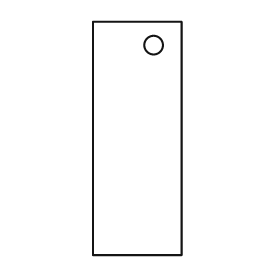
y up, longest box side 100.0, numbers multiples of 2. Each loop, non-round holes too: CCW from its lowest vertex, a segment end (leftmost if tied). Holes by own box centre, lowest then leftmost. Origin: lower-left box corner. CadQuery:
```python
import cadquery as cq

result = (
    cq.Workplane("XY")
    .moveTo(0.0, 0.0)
    .lineTo(38.0, 0.0)
    .lineTo(38.0, 100.0)
    .lineTo(0.0, 100.0)
    .close()
    .moveTo(26.0, 90.0)
    .circle(4.0)
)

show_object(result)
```